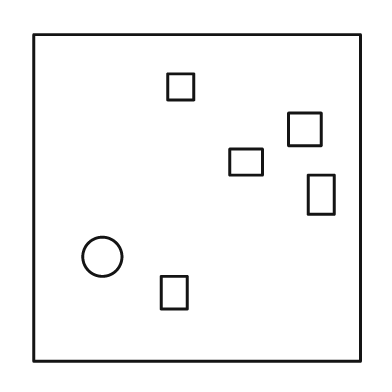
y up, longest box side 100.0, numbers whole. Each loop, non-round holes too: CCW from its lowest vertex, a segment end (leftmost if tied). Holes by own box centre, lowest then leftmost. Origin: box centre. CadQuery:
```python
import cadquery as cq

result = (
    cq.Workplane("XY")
    .moveTo(-50.0, -50.0)
    .lineTo(50.0, -50.0)
    .lineTo(50.0, 50.0)
    .lineTo(-50.0, 50.0)
    .close()
    .moveTo(-11.0, -34.0)
    .lineTo(-3.0, -34.0)
    .lineTo(-3.0, -24.0)
    .lineTo(-11.0, -24.0)
    .close()
    .moveTo(-29.0, -18.0)
    .circle(6.0)
    .moveTo(34.0, -5.0)
    .lineTo(42.0, -5.0)
    .lineTo(42.0, 7.0)
    .lineTo(34.0, 7.0)
    .close()
    .moveTo(10.0, 7.0)
    .lineTo(20.0, 7.0)
    .lineTo(20.0, 15.0)
    .lineTo(10.0, 15.0)
    .close()
    .moveTo(28.0, 16.0)
    .lineTo(38.0, 16.0)
    .lineTo(38.0, 26.0)
    .lineTo(28.0, 26.0)
    .close()
    .moveTo(-9.0, 30.0)
    .lineTo(-1.0, 30.0)
    .lineTo(-1.0, 38.0)
    .lineTo(-9.0, 38.0)
    .close()
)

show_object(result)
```